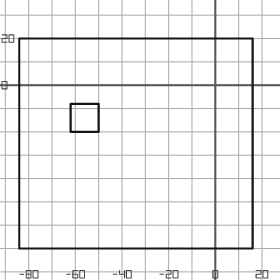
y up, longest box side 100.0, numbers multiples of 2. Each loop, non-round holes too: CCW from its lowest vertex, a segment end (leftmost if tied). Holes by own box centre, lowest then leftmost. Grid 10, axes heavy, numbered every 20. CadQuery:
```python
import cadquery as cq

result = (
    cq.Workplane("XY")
    .moveTo(-84.0, -70.0)
    .lineTo(16.0, -70.0)
    .lineTo(16.0, 20.0)
    .lineTo(-84.0, 20.0)
    .close()
    .moveTo(-62.0, -20.0)
    .lineTo(-50.0, -20.0)
    .lineTo(-50.0, -8.0)
    .lineTo(-62.0, -8.0)
    .close()
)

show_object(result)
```